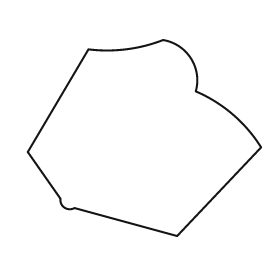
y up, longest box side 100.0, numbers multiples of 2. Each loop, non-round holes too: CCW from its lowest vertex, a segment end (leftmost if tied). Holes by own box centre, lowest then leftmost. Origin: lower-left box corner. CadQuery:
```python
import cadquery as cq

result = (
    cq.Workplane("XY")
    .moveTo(64.0, 0.0)
    .lineTo(100.0, 38.0)
    .threePointArc((88.0, 52.0), (72.0, 62.0))
    .threePointArc((70.0, 76.0), (58.0, 84.0))
    .threePointArc((42.0, 80.0), (26.0, 80.0))
    .lineTo(0.0, 36.0)
    .lineTo(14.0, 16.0)
    .threePointArc((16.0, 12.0), (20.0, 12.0))
    .close()
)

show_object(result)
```